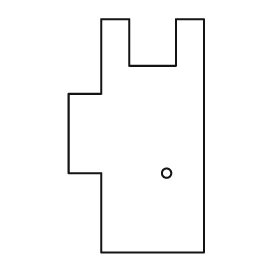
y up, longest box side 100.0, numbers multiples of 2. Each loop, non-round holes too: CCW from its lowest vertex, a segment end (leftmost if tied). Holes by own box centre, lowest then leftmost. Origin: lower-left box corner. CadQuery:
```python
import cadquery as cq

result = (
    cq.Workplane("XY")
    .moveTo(14.0, 0.0)
    .lineTo(58.0, 0.0)
    .lineTo(58.0, 100.0)
    .lineTo(46.0, 100.0)
    .lineTo(46.0, 80.0)
    .lineTo(26.0, 80.0)
    .lineTo(26.0, 100.0)
    .lineTo(14.0, 100.0)
    .lineTo(14.0, 68.0)
    .lineTo(0.0, 68.0)
    .lineTo(0.0, 34.0)
    .lineTo(14.0, 34.0)
    .close()
    .moveTo(42.0, 34.0)
    .circle(2.0)
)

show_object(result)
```